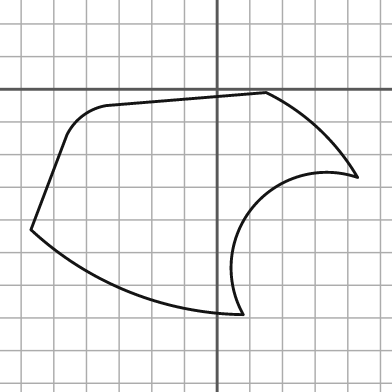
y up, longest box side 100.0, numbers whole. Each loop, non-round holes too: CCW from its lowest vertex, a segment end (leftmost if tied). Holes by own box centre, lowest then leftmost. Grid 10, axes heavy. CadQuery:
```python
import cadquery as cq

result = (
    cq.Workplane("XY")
    .moveTo(8.0, -69.0)
    .threePointArc((11.0, -36.0), (43.0, -27.0))
    .threePointArc((31.0, -12.0), (15.0, -1.0))
    .lineTo(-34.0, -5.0)
    .threePointArc((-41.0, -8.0), (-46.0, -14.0))
    .lineTo(-57.0, -43.0)
    .threePointArc((-27.0, -62.0), (8.0, -69.0))
    .close()
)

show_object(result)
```